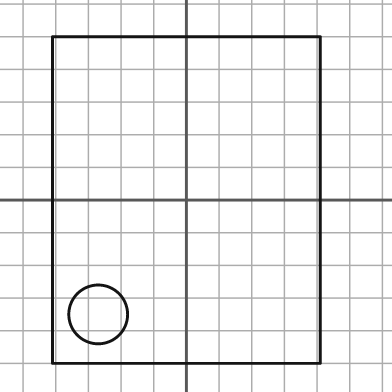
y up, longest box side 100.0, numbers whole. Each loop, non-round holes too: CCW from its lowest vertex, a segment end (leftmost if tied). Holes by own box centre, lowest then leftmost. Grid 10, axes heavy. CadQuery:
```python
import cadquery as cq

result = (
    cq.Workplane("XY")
    .moveTo(-41.0, -50.0)
    .lineTo(41.0, -50.0)
    .lineTo(41.0, 50.0)
    .lineTo(-41.0, 50.0)
    .close()
    .moveTo(-27.0, -35.0)
    .circle(9.0)
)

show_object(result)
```